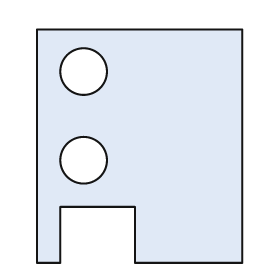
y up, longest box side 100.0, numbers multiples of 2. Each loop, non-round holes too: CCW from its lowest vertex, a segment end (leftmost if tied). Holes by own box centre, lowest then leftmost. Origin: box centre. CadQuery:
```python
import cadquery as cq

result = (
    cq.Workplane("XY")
    .moveTo(-44.0, -50.0)
    .lineTo(-34.0, -50.0)
    .lineTo(-34.0, -26.0)
    .lineTo(-2.0, -26.0)
    .lineTo(-2.0, -50.0)
    .lineTo(44.0, -50.0)
    .lineTo(44.0, 50.0)
    .lineTo(-44.0, 50.0)
    .close()
    .moveTo(-24.0, -6.0)
    .circle(10.0)
    .moveTo(-24.0, 32.0)
    .circle(10.0)
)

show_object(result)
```